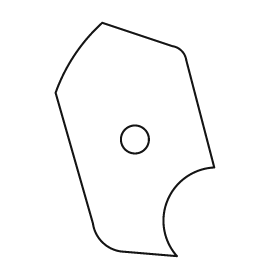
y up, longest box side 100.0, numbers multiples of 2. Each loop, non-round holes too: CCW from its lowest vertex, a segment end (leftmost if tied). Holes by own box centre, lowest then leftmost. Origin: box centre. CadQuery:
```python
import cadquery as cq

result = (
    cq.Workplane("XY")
    .moveTo(18.0, -50.0)
    .threePointArc((14.0, -26.0), (34.0, -12.0))
    .lineTo(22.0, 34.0)
    .threePointArc((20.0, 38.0), (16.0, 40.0))
    .lineTo(-14.0, 50.0)
    .threePointArc((-26.0, 36.0), (-34.0, 20.0))
    .lineTo(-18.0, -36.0)
    .threePointArc((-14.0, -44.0), (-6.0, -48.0))
    .close()
    .moveTo(0.0, 0.0)
    .circle(6.0)
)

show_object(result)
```